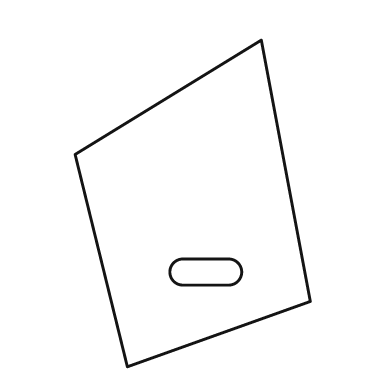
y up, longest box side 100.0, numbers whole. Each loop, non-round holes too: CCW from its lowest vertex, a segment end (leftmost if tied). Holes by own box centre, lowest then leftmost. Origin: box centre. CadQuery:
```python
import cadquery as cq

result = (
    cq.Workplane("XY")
    .moveTo(-20.0, -50.0)
    .lineTo(36.0, -30.0)
    .lineTo(21.0, 50.0)
    .lineTo(-36.0, 15.0)
    .close()
    .moveTo(-3.0, -25.0)
    .lineTo(11.0, -25.0)
    .threePointArc((15.0, -21.0), (11.0, -17.0))
    .lineTo(-3.0, -17.0)
    .threePointArc((-7.0, -21.0), (-3.0, -25.0))
    .close()
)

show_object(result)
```